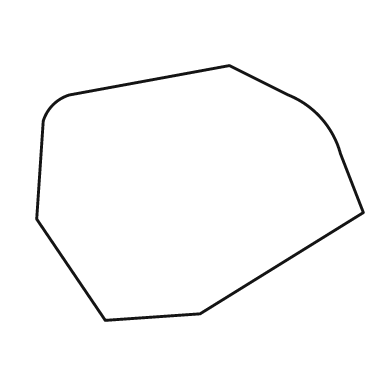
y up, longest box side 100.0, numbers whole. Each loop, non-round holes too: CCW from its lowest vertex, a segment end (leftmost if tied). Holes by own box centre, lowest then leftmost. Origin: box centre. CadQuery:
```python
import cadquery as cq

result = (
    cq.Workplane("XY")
    .moveTo(-29.0, -39.0)
    .lineTo(0.0, -37.0)
    .lineTo(50.0, -6.0)
    .lineTo(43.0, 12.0)
    .threePointArc((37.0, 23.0), (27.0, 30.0))
    .lineTo(9.0, 39.0)
    .lineTo(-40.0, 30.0)
    .threePointArc((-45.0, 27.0), (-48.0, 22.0))
    .lineTo(-50.0, -8.0)
    .close()
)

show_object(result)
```